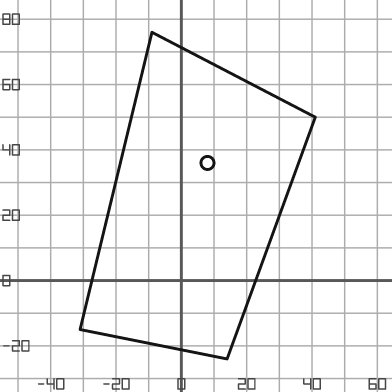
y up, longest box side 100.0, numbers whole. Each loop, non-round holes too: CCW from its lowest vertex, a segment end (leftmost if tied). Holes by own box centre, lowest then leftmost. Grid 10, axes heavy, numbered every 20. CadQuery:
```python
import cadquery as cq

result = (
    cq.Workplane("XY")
    .moveTo(14.0, -24.0)
    .lineTo(41.0, 50.0)
    .lineTo(-9.0, 76.0)
    .lineTo(-31.0, -15.0)
    .close()
    .moveTo(8.0, 36.0)
    .circle(2.0)
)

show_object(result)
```